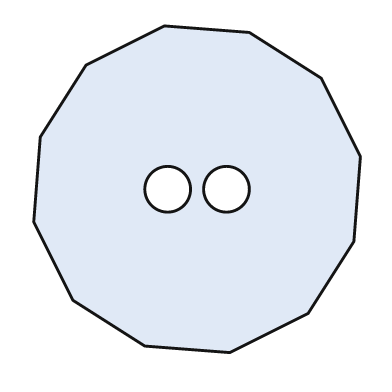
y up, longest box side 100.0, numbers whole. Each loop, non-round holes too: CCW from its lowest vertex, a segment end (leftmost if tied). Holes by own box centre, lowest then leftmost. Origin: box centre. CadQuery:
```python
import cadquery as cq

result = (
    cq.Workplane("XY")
    .moveTo(10.0, -50.0)
    .lineTo(34.0, -38.0)
    .lineTo(48.0, -16.0)
    .lineTo(50.0, 10.0)
    .lineTo(38.0, 34.0)
    .lineTo(16.0, 48.0)
    .lineTo(-10.0, 50.0)
    .lineTo(-34.0, 38.0)
    .lineTo(-48.0, 16.0)
    .lineTo(-50.0, -10.0)
    .lineTo(-38.0, -34.0)
    .lineTo(-16.0, -48.0)
    .close()
    .moveTo(-9.0, 0.0)
    .circle(7.0)
    .moveTo(9.0, 0.0)
    .circle(7.0)
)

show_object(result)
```